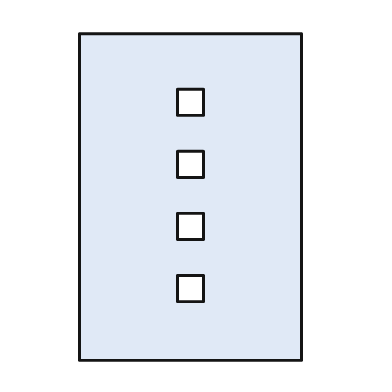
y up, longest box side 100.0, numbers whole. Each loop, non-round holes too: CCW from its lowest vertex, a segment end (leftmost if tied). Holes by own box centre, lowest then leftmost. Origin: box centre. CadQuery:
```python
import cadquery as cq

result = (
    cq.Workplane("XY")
    .moveTo(-34.0, -50.0)
    .lineTo(34.0, -50.0)
    .lineTo(34.0, 50.0)
    .lineTo(-34.0, 50.0)
    .close()
    .moveTo(-4.0, -32.0)
    .lineTo(4.0, -32.0)
    .lineTo(4.0, -24.0)
    .lineTo(-4.0, -24.0)
    .close()
    .moveTo(-4.0, -13.0)
    .lineTo(4.0, -13.0)
    .lineTo(4.0, -5.0)
    .lineTo(-4.0, -5.0)
    .close()
    .moveTo(-4.0, 6.0)
    .lineTo(4.0, 6.0)
    .lineTo(4.0, 14.0)
    .lineTo(-4.0, 14.0)
    .close()
    .moveTo(-4.0, 25.0)
    .lineTo(4.0, 25.0)
    .lineTo(4.0, 33.0)
    .lineTo(-4.0, 33.0)
    .close()
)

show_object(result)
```